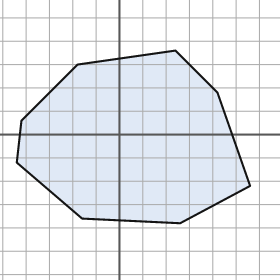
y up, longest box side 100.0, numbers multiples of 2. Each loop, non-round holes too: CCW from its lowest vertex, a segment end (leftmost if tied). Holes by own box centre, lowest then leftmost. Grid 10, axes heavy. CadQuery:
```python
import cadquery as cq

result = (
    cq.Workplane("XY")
    .moveTo(26.0, -38.0)
    .lineTo(56.0, -22.0)
    .lineTo(42.0, 18.0)
    .lineTo(24.0, 36.0)
    .lineTo(-18.0, 30.0)
    .lineTo(-42.0, 6.0)
    .lineTo(-44.0, -12.0)
    .lineTo(-16.0, -36.0)
    .close()
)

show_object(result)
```